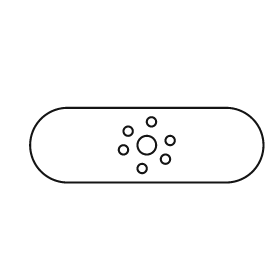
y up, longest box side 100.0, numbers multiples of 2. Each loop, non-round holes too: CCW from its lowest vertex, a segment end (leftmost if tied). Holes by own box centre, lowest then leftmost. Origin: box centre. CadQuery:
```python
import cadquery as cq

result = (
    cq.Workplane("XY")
    .moveTo(-34.0, -16.0)
    .lineTo(34.0, -16.0)
    .threePointArc((50.0, 0.0), (34.0, 16.0))
    .lineTo(-34.0, 16.0)
    .threePointArc((-50.0, 0.0), (-34.0, -16.0))
    .close()
    .moveTo(-2.0, -10.0)
    .circle(2.0)
    .moveTo(8.0, -6.0)
    .circle(2.0)
    .moveTo(-10.0, -2.0)
    .circle(2.0)
    .moveTo(0.0, 0.0)
    .circle(4.0)
    .moveTo(10.0, 2.0)
    .circle(2.0)
    .moveTo(-8.0, 6.0)
    .circle(2.0)
    .moveTo(2.0, 10.0)
    .circle(2.0)
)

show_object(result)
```